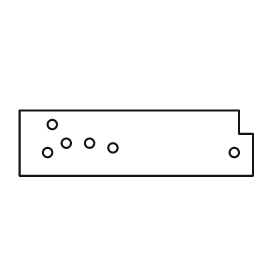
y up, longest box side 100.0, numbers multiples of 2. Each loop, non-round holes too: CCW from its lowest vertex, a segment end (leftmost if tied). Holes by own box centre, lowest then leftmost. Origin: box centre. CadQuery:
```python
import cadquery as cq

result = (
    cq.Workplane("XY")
    .moveTo(-50.0, -14.0)
    .lineTo(50.0, -14.0)
    .lineTo(50.0, 4.0)
    .lineTo(44.0, 4.0)
    .lineTo(44.0, 14.0)
    .lineTo(-50.0, 14.0)
    .close()
    .moveTo(-38.0, -4.0)
    .circle(2.0)
    .moveTo(42.0, -4.0)
    .circle(2.0)
    .moveTo(-10.0, -2.0)
    .circle(2.0)
    .moveTo(-30.0, 0.0)
    .circle(2.0)
    .moveTo(-20.0, 0.0)
    .circle(2.0)
    .moveTo(-36.0, 8.0)
    .circle(2.0)
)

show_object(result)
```